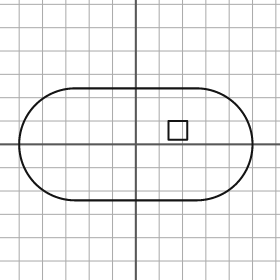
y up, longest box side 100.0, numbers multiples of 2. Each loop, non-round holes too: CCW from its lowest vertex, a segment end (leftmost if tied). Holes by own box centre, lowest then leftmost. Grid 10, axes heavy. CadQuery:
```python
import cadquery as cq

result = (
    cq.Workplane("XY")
    .moveTo(-26.0, -24.0)
    .lineTo(26.0, -24.0)
    .threePointArc((50.0, 0.0), (26.0, 24.0))
    .lineTo(-26.0, 24.0)
    .threePointArc((-50.0, 0.0), (-26.0, -24.0))
    .close()
    .moveTo(14.0, 2.0)
    .lineTo(22.0, 2.0)
    .lineTo(22.0, 10.0)
    .lineTo(14.0, 10.0)
    .close()
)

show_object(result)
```